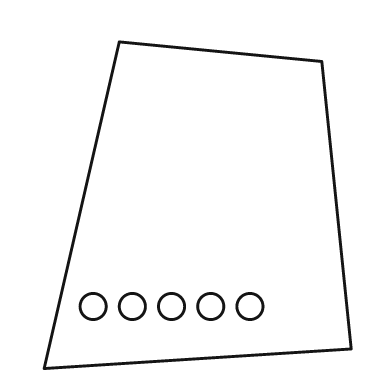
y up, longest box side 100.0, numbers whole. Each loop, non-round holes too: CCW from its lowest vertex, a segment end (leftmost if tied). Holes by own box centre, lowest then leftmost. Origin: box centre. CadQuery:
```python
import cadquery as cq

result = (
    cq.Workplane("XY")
    .moveTo(-47.0, -50.0)
    .lineTo(47.0, -44.0)
    .lineTo(38.0, 44.0)
    .lineTo(-24.0, 50.0)
    .close()
    .moveTo(-32.0, -31.0)
    .circle(4.0)
    .moveTo(-20.0, -31.0)
    .circle(4.0)
    .moveTo(-8.0, -31.0)
    .circle(4.0)
    .moveTo(4.0, -31.0)
    .circle(4.0)
    .moveTo(16.0, -31.0)
    .circle(4.0)
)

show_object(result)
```